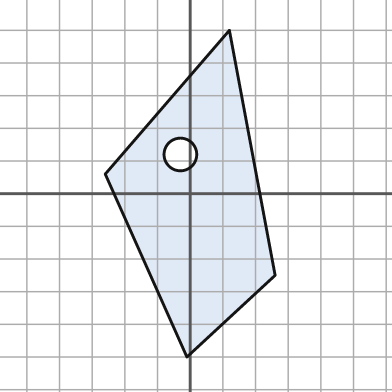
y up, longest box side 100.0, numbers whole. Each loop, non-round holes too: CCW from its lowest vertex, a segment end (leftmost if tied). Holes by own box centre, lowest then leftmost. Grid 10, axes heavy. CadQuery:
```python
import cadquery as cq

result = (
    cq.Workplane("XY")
    .moveTo(-1.0, -50.0)
    .lineTo(26.0, -25.0)
    .lineTo(12.0, 50.0)
    .lineTo(-26.0, 6.0)
    .close()
    .moveTo(-3.0, 12.0)
    .circle(5.0)
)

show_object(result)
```